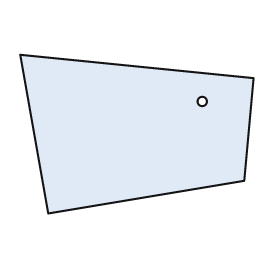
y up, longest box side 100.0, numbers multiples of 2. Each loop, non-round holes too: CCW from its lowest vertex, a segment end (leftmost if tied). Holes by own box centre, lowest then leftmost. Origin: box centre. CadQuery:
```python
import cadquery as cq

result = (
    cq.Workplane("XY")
    .moveTo(-38.0, -34.0)
    .lineTo(46.0, -20.0)
    .lineTo(50.0, 24.0)
    .lineTo(-50.0, 34.0)
    .close()
    .moveTo(28.0, 14.0)
    .circle(2.0)
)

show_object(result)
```